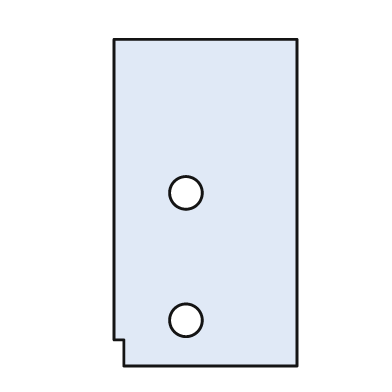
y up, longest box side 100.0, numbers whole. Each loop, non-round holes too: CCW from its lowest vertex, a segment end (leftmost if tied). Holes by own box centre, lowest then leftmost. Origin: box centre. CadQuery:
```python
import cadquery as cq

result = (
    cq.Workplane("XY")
    .moveTo(-25.0, -50.0)
    .lineTo(28.0, -50.0)
    .lineTo(28.0, 50.0)
    .lineTo(-28.0, 50.0)
    .lineTo(-28.0, -42.0)
    .lineTo(-25.0, -42.0)
    .close()
    .moveTo(-6.0, -36.0)
    .circle(5.0)
    .moveTo(-6.0, 3.0)
    .circle(5.0)
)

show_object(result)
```